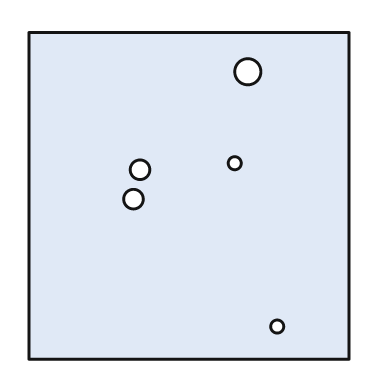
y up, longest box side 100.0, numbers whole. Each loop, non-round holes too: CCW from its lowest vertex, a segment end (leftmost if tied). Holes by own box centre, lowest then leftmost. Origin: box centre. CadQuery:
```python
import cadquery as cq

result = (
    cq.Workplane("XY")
    .moveTo(-49.0, -50.0)
    .lineTo(49.0, -50.0)
    .lineTo(49.0, 50.0)
    .lineTo(-49.0, 50.0)
    .close()
    .moveTo(27.0, -40.0)
    .circle(2.0)
    .moveTo(-17.0, -1.0)
    .circle(3.0)
    .moveTo(-15.0, 8.0)
    .circle(3.0)
    .moveTo(14.0, 10.0)
    .circle(2.0)
    .moveTo(18.0, 38.0)
    .circle(4.0)
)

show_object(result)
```